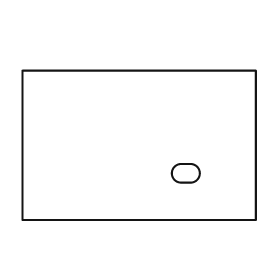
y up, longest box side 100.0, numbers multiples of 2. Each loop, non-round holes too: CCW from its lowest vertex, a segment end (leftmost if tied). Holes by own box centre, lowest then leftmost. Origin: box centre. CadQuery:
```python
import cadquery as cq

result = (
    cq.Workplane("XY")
    .moveTo(-50.0, -32.0)
    .lineTo(50.0, -32.0)
    .lineTo(50.0, 32.0)
    .lineTo(-50.0, 32.0)
    .close()
    .moveTo(18.0, -16.0)
    .lineTo(22.0, -16.0)
    .threePointArc((26.0, -12.0), (22.0, -8.0))
    .lineTo(18.0, -8.0)
    .threePointArc((14.0, -12.0), (18.0, -16.0))
    .close()
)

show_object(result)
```